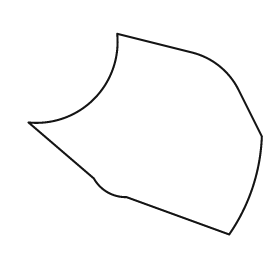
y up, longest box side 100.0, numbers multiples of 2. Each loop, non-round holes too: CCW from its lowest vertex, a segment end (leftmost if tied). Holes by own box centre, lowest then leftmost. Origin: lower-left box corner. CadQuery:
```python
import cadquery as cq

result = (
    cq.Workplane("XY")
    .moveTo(86.0, 0.0)
    .threePointArc((96.0, 20.0), (100.0, 42.0))
    .lineTo(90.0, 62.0)
    .threePointArc((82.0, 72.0), (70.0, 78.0))
    .lineTo(38.0, 86.0)
    .threePointArc((28.0, 58.0), (0.0, 48.0))
    .lineTo(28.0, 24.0)
    .threePointArc((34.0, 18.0), (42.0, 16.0))
    .close()
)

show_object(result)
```